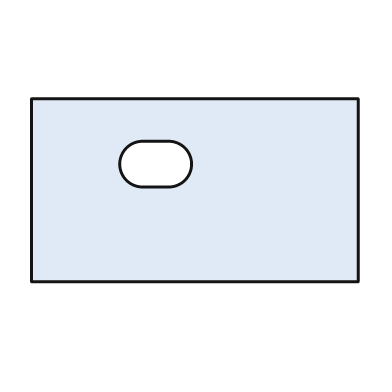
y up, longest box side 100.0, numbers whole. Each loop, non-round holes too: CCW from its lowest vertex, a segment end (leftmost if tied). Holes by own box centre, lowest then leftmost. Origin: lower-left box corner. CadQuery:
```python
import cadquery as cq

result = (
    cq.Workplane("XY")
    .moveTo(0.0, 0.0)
    .lineTo(100.0, 0.0)
    .lineTo(100.0, 56.0)
    .lineTo(0.0, 56.0)
    .close()
    .moveTo(34.0, 29.0)
    .lineTo(42.0, 29.0)
    .threePointArc((49.0, 36.0), (42.0, 43.0))
    .lineTo(34.0, 43.0)
    .threePointArc((27.0, 36.0), (34.0, 29.0))
    .close()
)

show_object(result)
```